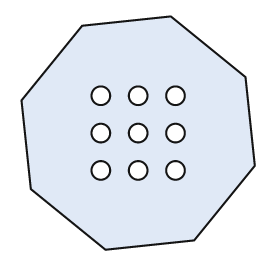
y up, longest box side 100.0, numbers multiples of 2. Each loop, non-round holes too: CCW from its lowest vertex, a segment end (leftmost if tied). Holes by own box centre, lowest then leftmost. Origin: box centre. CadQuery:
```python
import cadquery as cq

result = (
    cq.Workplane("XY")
    .moveTo(-14.0, -50.0)
    .lineTo(24.0, -46.0)
    .lineTo(50.0, -14.0)
    .lineTo(46.0, 24.0)
    .lineTo(14.0, 50.0)
    .lineTo(-24.0, 46.0)
    .lineTo(-50.0, 14.0)
    .lineTo(-46.0, -24.0)
    .close()
    .moveTo(-16.0, -16.0)
    .circle(4.0)
    .moveTo(0.0, -16.0)
    .circle(4.0)
    .moveTo(16.0, -16.0)
    .circle(4.0)
    .moveTo(-16.0, 0.0)
    .circle(4.0)
    .moveTo(0.0, 0.0)
    .circle(4.0)
    .moveTo(16.0, 0.0)
    .circle(4.0)
    .moveTo(-16.0, 16.0)
    .circle(4.0)
    .moveTo(0.0, 16.0)
    .circle(4.0)
    .moveTo(16.0, 16.0)
    .circle(4.0)
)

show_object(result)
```